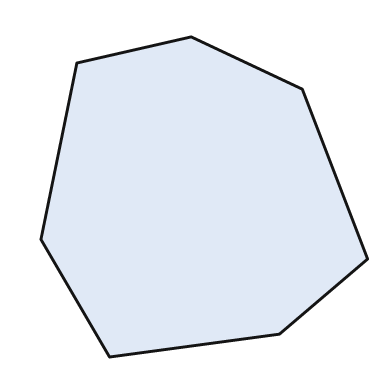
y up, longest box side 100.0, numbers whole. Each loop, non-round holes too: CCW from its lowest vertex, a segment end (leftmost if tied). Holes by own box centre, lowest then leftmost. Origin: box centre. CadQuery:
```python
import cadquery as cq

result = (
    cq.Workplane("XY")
    .moveTo(-29.0, -49.0)
    .lineTo(23.0, -42.0)
    .lineTo(50.0, -19.0)
    .lineTo(30.0, 33.0)
    .lineTo(-4.0, 49.0)
    .lineTo(-39.0, 41.0)
    .lineTo(-50.0, -13.0)
    .close()
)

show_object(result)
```